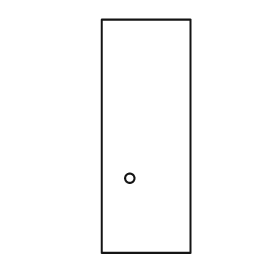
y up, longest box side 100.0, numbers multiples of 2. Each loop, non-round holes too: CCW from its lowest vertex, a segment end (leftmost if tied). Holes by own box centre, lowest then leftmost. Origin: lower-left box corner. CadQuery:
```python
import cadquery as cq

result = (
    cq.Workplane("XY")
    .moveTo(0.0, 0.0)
    .lineTo(38.0, 0.0)
    .lineTo(38.0, 100.0)
    .lineTo(0.0, 100.0)
    .close()
    .moveTo(12.0, 32.0)
    .circle(2.0)
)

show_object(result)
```